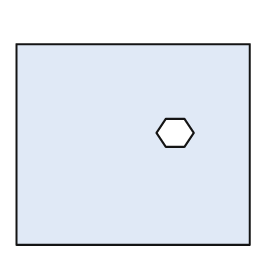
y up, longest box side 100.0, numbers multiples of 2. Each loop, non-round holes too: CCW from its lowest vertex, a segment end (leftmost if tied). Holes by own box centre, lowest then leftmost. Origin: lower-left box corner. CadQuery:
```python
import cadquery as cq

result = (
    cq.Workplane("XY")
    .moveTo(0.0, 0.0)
    .lineTo(100.0, 0.0)
    .lineTo(100.0, 86.0)
    .lineTo(0.0, 86.0)
    .close()
    .moveTo(64.0, 42.0)
    .lineTo(72.0, 42.0)
    .lineTo(76.0, 48.0)
    .lineTo(72.0, 54.0)
    .lineTo(64.0, 54.0)
    .lineTo(60.0, 48.0)
    .close()
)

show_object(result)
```